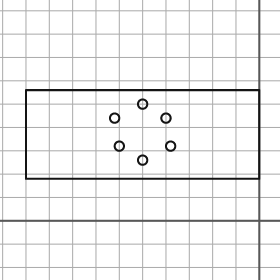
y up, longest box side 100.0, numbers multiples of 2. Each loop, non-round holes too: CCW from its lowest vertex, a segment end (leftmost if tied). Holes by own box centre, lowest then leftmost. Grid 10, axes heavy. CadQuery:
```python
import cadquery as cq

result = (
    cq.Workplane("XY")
    .moveTo(-100.0, 18.0)
    .lineTo(0.0, 18.0)
    .lineTo(0.0, 56.0)
    .lineTo(-100.0, 56.0)
    .close()
    .moveTo(-50.0, 26.0)
    .circle(2.0)
    .moveTo(-60.0, 32.0)
    .circle(2.0)
    .moveTo(-38.0, 32.0)
    .circle(2.0)
    .moveTo(-62.0, 44.0)
    .circle(2.0)
    .moveTo(-40.0, 44.0)
    .circle(2.0)
    .moveTo(-50.0, 50.0)
    .circle(2.0)
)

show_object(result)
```